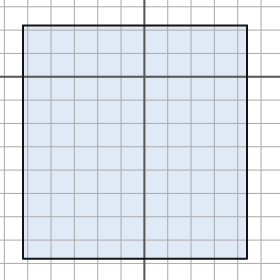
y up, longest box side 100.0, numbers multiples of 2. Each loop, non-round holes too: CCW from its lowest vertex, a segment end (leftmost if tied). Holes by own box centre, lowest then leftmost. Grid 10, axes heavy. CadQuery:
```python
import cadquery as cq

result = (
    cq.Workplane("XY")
    .moveTo(-52.0, -78.0)
    .lineTo(44.0, -78.0)
    .lineTo(44.0, 22.0)
    .lineTo(-52.0, 22.0)
    .close()
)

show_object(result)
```